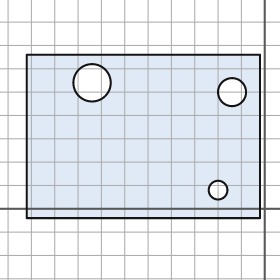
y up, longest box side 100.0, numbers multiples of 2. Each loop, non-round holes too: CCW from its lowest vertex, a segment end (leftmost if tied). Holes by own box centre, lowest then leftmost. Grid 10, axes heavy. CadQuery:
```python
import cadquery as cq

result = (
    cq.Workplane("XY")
    .moveTo(-102.0, -4.0)
    .lineTo(-2.0, -4.0)
    .lineTo(-2.0, 66.0)
    .lineTo(-102.0, 66.0)
    .close()
    .moveTo(-20.0, 8.0)
    .circle(4.0)
    .moveTo(-14.0, 50.0)
    .circle(6.0)
    .moveTo(-74.0, 54.0)
    .circle(8.0)
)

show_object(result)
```